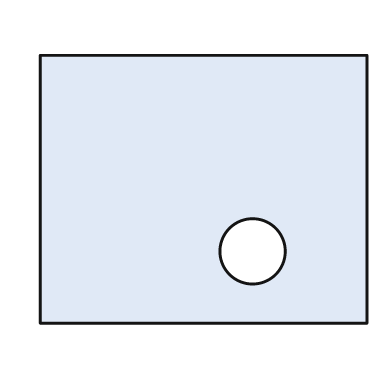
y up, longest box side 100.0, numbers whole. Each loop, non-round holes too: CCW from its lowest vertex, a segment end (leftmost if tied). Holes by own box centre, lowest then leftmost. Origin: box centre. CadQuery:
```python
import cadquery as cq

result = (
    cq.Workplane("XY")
    .moveTo(-50.0, -41.0)
    .lineTo(50.0, -41.0)
    .lineTo(50.0, 41.0)
    .lineTo(-50.0, 41.0)
    .close()
    .moveTo(15.0, -19.0)
    .circle(10.0)
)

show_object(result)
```